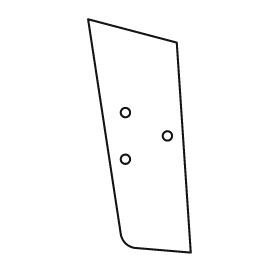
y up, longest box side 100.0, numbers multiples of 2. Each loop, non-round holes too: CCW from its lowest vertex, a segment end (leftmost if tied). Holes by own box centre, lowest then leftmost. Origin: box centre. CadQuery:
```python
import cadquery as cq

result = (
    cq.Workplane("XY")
    .moveTo(22.0, -50.0)
    .lineTo(16.0, 40.0)
    .lineTo(-22.0, 50.0)
    .lineTo(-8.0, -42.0)
    .threePointArc((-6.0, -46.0), (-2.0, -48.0))
    .close()
    .moveTo(-6.0, -10.0)
    .circle(2.0)
    .moveTo(12.0, 0.0)
    .circle(2.0)
    .moveTo(-6.0, 10.0)
    .circle(2.0)
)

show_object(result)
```